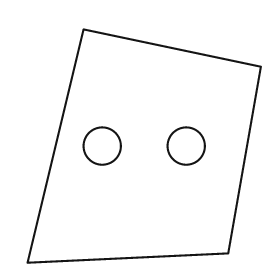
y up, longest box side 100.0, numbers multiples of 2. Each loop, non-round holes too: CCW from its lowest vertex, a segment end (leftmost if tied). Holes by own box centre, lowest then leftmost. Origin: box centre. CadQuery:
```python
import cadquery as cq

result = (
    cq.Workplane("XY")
    .moveTo(-50.0, -50.0)
    .lineTo(36.0, -46.0)
    .lineTo(50.0, 34.0)
    .lineTo(-26.0, 50.0)
    .close()
    .moveTo(-18.0, 0.0)
    .circle(8.0)
    .moveTo(18.0, 0.0)
    .circle(8.0)
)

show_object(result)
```